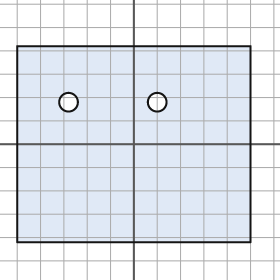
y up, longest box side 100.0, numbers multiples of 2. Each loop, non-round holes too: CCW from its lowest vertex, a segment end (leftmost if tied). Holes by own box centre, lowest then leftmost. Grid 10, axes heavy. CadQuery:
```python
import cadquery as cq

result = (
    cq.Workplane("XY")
    .moveTo(-50.0, -42.0)
    .lineTo(50.0, -42.0)
    .lineTo(50.0, 42.0)
    .lineTo(-50.0, 42.0)
    .close()
    .moveTo(-28.0, 18.0)
    .circle(4.0)
    .moveTo(10.0, 18.0)
    .circle(4.0)
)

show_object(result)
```